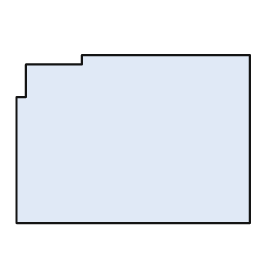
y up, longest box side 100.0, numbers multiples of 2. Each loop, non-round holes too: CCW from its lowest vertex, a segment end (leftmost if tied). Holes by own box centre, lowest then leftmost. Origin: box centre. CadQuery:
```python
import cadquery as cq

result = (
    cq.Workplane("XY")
    .moveTo(-50.0, -36.0)
    .lineTo(50.0, -36.0)
    .lineTo(50.0, 36.0)
    .lineTo(-22.0, 36.0)
    .lineTo(-22.0, 32.0)
    .lineTo(-46.0, 32.0)
    .lineTo(-46.0, 18.0)
    .lineTo(-50.0, 18.0)
    .close()
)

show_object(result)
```